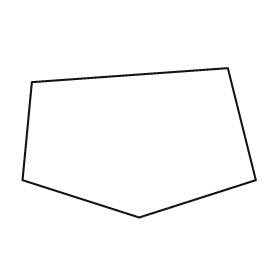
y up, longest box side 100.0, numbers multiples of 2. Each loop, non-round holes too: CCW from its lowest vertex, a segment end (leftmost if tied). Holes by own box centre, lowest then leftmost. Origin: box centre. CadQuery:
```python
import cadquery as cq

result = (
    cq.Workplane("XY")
    .moveTo(0.0, -32.0)
    .lineTo(50.0, -16.0)
    .lineTo(38.0, 32.0)
    .lineTo(-46.0, 26.0)
    .lineTo(-50.0, -16.0)
    .close()
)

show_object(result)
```